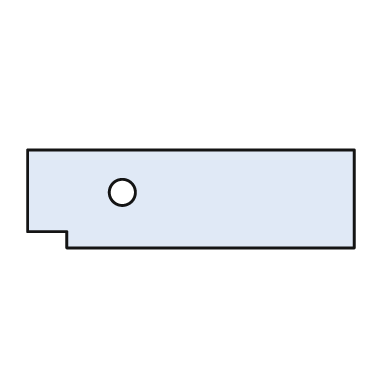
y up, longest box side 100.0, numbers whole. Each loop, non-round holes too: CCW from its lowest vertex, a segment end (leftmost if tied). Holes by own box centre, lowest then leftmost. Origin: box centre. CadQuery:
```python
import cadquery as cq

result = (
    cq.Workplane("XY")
    .moveTo(-38.0, -15.0)
    .lineTo(50.0, -15.0)
    .lineTo(50.0, 15.0)
    .lineTo(-50.0, 15.0)
    .lineTo(-50.0, -10.0)
    .lineTo(-38.0, -10.0)
    .close()
    .moveTo(-21.0, 2.0)
    .circle(4.0)
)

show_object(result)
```